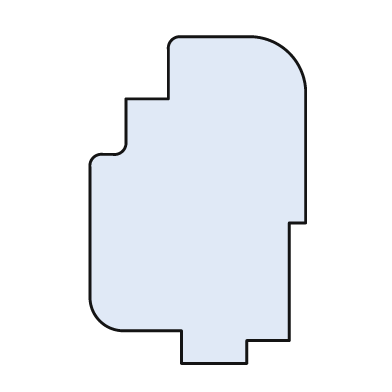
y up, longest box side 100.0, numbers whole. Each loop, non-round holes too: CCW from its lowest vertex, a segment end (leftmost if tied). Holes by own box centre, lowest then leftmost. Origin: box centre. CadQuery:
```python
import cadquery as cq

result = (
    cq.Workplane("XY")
    .moveTo(-5.0, -50.0)
    .lineTo(15.0, -50.0)
    .lineTo(15.0, -43.0)
    .lineTo(28.0, -43.0)
    .lineTo(28.0, -7.0)
    .lineTo(33.0, -7.0)
    .lineTo(33.0, 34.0)
    .threePointArc((28.0, 45.0), (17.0, 50.0))
    .lineTo(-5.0, 50.0)
    .threePointArc((-8.0, 49.0), (-9.0, 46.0))
    .lineTo(-9.0, 31.0)
    .lineTo(-22.0, 31.0)
    .lineTo(-22.0, 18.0)
    .threePointArc((-23.0, 15.0), (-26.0, 14.0))
    .lineTo(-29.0, 14.0)
    .threePointArc((-32.0, 13.0), (-33.0, 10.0))
    .lineTo(-33.0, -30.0)
    .threePointArc((-30.0, -37.0), (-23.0, -40.0))
    .lineTo(-5.0, -40.0)
    .close()
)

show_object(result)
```